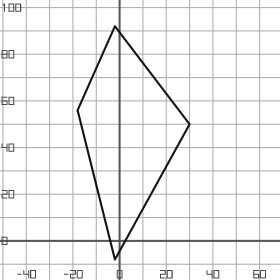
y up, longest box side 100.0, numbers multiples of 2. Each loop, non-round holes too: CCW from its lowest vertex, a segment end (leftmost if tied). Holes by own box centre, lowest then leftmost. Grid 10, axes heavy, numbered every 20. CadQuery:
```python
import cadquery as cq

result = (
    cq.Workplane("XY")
    .moveTo(-2.0, -8.0)
    .lineTo(30.0, 50.0)
    .lineTo(-2.0, 92.0)
    .lineTo(-18.0, 56.0)
    .close()
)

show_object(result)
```